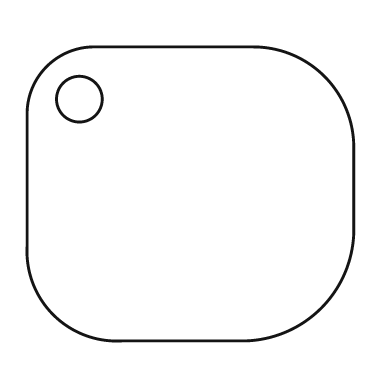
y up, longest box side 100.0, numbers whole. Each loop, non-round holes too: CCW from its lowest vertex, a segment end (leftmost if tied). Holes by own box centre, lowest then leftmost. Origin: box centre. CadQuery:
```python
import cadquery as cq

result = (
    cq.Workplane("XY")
    .moveTo(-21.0, -45.0)
    .lineTo(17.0, -45.0)
    .threePointArc((40.0, -35.0), (50.0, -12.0))
    .lineTo(50.0, 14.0)
    .threePointArc((41.0, 36.0), (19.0, 45.0))
    .lineTo(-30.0, 45.0)
    .threePointArc((-44.0, 39.0), (-50.0, 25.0))
    .lineTo(-50.0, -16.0)
    .threePointArc((-42.0, -37.0), (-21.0, -45.0))
    .close()
    .moveTo(-34.0, 29.0)
    .circle(7.0)
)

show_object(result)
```